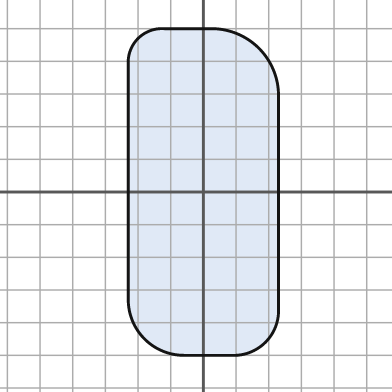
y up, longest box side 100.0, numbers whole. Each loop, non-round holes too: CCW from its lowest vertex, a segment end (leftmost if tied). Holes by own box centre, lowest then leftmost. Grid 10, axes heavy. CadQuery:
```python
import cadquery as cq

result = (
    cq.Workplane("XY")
    .moveTo(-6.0, -50.0)
    .lineTo(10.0, -50.0)
    .threePointArc((19.0, -46.0), (23.0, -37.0))
    .lineTo(23.0, 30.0)
    .threePointArc((17.0, 44.0), (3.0, 50.0))
    .lineTo(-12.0, 50.0)
    .threePointArc((-20.0, 47.0), (-23.0, 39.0))
    .lineTo(-23.0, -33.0)
    .threePointArc((-18.0, -45.0), (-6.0, -50.0))
    .close()
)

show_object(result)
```